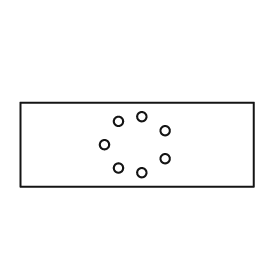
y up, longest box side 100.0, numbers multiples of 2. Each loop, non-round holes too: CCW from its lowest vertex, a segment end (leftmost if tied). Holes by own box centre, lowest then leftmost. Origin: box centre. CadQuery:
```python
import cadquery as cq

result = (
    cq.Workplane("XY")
    .moveTo(-50.0, -18.0)
    .lineTo(50.0, -18.0)
    .lineTo(50.0, 18.0)
    .lineTo(-50.0, 18.0)
    .close()
    .moveTo(2.0, -12.0)
    .circle(2.0)
    .moveTo(-8.0, -10.0)
    .circle(2.0)
    .moveTo(12.0, -6.0)
    .circle(2.0)
    .moveTo(-14.0, 0.0)
    .circle(2.0)
    .moveTo(12.0, 6.0)
    .circle(2.0)
    .moveTo(-8.0, 10.0)
    .circle(2.0)
    .moveTo(2.0, 12.0)
    .circle(2.0)
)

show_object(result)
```